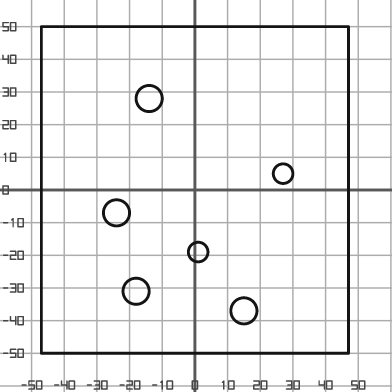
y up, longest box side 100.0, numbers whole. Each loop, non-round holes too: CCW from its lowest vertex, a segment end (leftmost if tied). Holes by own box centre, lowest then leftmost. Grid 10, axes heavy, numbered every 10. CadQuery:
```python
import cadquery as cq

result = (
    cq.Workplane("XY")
    .moveTo(-47.0, -50.0)
    .lineTo(47.0, -50.0)
    .lineTo(47.0, 50.0)
    .lineTo(-47.0, 50.0)
    .close()
    .moveTo(15.0, -37.0)
    .circle(4.0)
    .moveTo(-18.0, -31.0)
    .circle(4.0)
    .moveTo(1.0, -19.0)
    .circle(3.0)
    .moveTo(-24.0, -7.0)
    .circle(4.0)
    .moveTo(27.0, 5.0)
    .circle(3.0)
    .moveTo(-14.0, 28.0)
    .circle(4.0)
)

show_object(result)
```